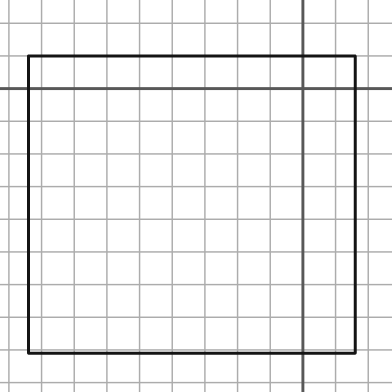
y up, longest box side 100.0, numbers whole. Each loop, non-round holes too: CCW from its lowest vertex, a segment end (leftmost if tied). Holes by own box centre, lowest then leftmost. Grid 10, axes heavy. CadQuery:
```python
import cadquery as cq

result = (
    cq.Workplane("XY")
    .moveTo(-84.0, -81.0)
    .lineTo(16.0, -81.0)
    .lineTo(16.0, 10.0)
    .lineTo(-84.0, 10.0)
    .close()
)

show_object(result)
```